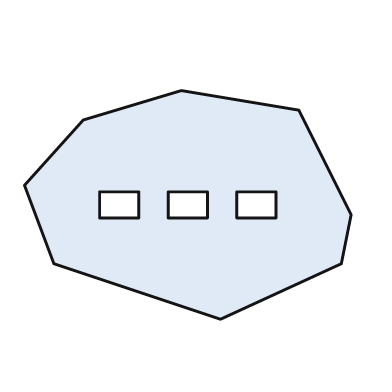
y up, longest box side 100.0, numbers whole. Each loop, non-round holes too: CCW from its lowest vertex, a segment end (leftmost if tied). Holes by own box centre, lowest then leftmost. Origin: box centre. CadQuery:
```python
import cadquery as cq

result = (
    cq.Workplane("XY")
    .moveTo(10.0, -35.0)
    .lineTo(47.0, -18.0)
    .lineTo(50.0, -3.0)
    .lineTo(34.0, 29.0)
    .lineTo(-2.0, 35.0)
    .lineTo(-32.0, 26.0)
    .lineTo(-50.0, 6.0)
    .lineTo(-41.0, -18.0)
    .close()
    .moveTo(-27.0, -4.0)
    .lineTo(-15.0, -4.0)
    .lineTo(-15.0, 4.0)
    .lineTo(-27.0, 4.0)
    .close()
    .moveTo(-6.0, -4.0)
    .lineTo(6.0, -4.0)
    .lineTo(6.0, 4.0)
    .lineTo(-6.0, 4.0)
    .close()
    .moveTo(15.0, -4.0)
    .lineTo(27.0, -4.0)
    .lineTo(27.0, 4.0)
    .lineTo(15.0, 4.0)
    .close()
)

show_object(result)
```